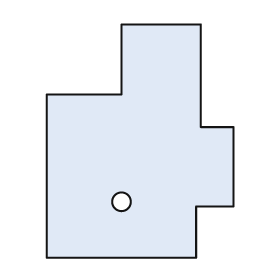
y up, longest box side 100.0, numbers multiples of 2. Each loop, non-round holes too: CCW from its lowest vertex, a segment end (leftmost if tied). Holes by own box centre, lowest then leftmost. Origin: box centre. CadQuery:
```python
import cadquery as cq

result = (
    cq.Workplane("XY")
    .moveTo(-40.0, -50.0)
    .lineTo(24.0, -50.0)
    .lineTo(24.0, -28.0)
    .lineTo(40.0, -28.0)
    .lineTo(40.0, 6.0)
    .lineTo(26.0, 6.0)
    .lineTo(26.0, 50.0)
    .lineTo(-8.0, 50.0)
    .lineTo(-8.0, 20.0)
    .lineTo(-40.0, 20.0)
    .close()
    .moveTo(-8.0, -26.0)
    .circle(4.0)
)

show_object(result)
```